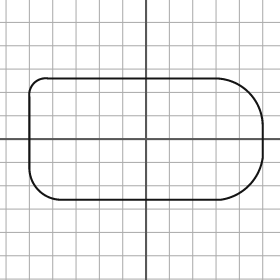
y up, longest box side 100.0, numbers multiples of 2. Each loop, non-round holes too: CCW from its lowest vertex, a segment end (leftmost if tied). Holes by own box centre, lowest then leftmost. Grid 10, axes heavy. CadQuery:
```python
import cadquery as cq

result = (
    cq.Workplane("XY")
    .moveTo(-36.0, -26.0)
    .lineTo(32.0, -26.0)
    .threePointArc((44.0, -20.0), (50.0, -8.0))
    .lineTo(50.0, 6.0)
    .threePointArc((44.0, 20.0), (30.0, 26.0))
    .lineTo(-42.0, 26.0)
    .threePointArc((-48.0, 24.0), (-50.0, 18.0))
    .lineTo(-50.0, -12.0)
    .threePointArc((-46.0, -22.0), (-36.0, -26.0))
    .close()
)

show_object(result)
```